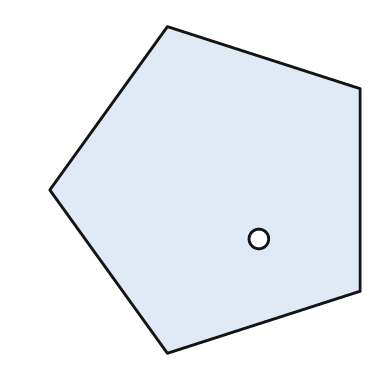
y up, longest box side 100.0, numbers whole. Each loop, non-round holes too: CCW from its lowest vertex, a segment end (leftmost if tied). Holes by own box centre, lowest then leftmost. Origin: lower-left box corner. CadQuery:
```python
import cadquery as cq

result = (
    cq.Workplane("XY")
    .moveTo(36.0, 0.0)
    .lineTo(95.0, 19.0)
    .lineTo(95.0, 81.0)
    .lineTo(36.0, 100.0)
    .lineTo(0.0, 50.0)
    .close()
    .moveTo(64.0, 35.0)
    .circle(3.0)
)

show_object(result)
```